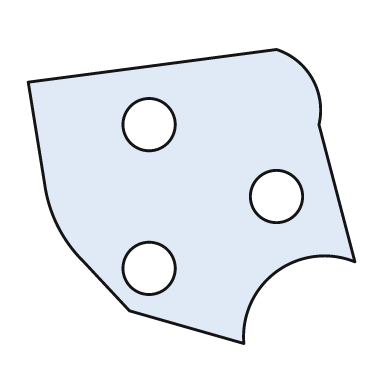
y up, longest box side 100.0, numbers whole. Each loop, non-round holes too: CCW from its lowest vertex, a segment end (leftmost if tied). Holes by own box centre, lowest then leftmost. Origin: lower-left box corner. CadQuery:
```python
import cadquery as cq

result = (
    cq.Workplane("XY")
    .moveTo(66.0, 0.0)
    .threePointArc((76.0, 22.0), (100.0, 25.0))
    .lineTo(89.0, 67.0)
    .threePointArc((87.0, 81.0), (76.0, 90.0))
    .lineTo(0.0, 80.0)
    .lineTo(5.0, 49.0)
    .threePointArc((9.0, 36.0), (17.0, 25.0))
    .lineTo(31.0, 10.0)
    .close()
    .moveTo(37.0, 23.0)
    .circle(8.0)
    .moveTo(76.0, 45.0)
    .circle(8.0)
    .moveTo(37.0, 67.0)
    .circle(8.0)
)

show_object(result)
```